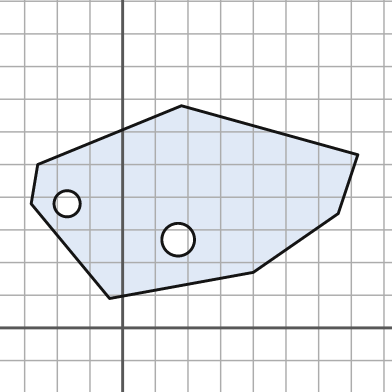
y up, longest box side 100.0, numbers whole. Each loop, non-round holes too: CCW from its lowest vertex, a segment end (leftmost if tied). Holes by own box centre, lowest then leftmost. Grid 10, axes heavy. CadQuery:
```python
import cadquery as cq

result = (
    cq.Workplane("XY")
    .moveTo(-4.0, 9.0)
    .lineTo(40.0, 17.0)
    .lineTo(66.0, 35.0)
    .lineTo(72.0, 53.0)
    .lineTo(18.0, 68.0)
    .lineTo(-26.0, 50.0)
    .lineTo(-28.0, 38.0)
    .close()
    .moveTo(17.0, 27.0)
    .circle(5.0)
    .moveTo(-17.0, 38.0)
    .circle(4.0)
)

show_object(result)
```